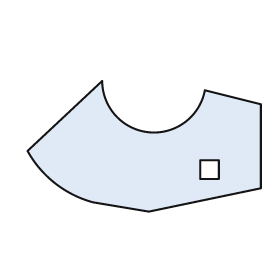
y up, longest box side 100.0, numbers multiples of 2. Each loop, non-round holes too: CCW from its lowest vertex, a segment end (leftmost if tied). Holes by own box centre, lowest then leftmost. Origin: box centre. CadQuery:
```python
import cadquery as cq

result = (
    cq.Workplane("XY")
    .moveTo(2.0, -28.0)
    .lineTo(50.0, -18.0)
    .lineTo(50.0, 18.0)
    .lineTo(26.0, 24.0)
    .threePointArc((2.0, 6.0), (-18.0, 28.0))
    .lineTo(-50.0, -2.0)
    .threePointArc((-38.0, -16.0), (-22.0, -24.0))
    .close()
    .moveTo(24.0, -14.0)
    .lineTo(32.0, -14.0)
    .lineTo(32.0, -6.0)
    .lineTo(24.0, -6.0)
    .close()
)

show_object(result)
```